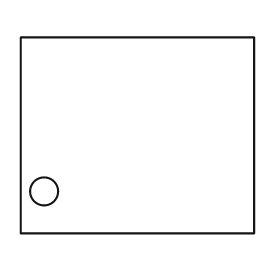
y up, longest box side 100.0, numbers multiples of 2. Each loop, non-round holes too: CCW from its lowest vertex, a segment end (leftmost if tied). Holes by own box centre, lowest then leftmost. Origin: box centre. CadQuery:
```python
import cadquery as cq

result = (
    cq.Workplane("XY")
    .moveTo(-50.0, -42.0)
    .lineTo(50.0, -42.0)
    .lineTo(50.0, 42.0)
    .lineTo(-50.0, 42.0)
    .close()
    .moveTo(-40.0, -24.0)
    .circle(6.0)
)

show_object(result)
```